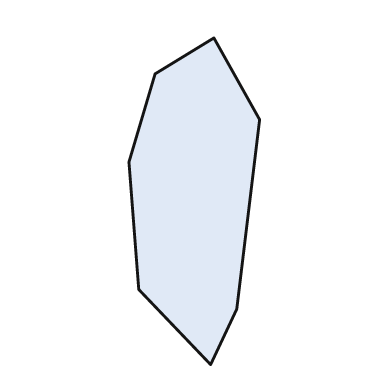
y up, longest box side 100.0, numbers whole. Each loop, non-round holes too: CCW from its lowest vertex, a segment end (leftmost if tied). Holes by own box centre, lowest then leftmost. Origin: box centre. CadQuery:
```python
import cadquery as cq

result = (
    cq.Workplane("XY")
    .moveTo(5.0, -50.0)
    .lineTo(13.0, -33.0)
    .lineTo(20.0, 25.0)
    .lineTo(6.0, 50.0)
    .lineTo(-12.0, 39.0)
    .lineTo(-20.0, 12.0)
    .lineTo(-17.0, -27.0)
    .close()
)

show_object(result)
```